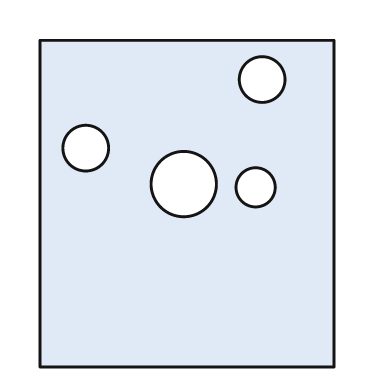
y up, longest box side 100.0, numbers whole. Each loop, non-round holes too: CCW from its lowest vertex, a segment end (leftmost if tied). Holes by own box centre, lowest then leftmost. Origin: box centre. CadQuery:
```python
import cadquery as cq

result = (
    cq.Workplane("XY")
    .moveTo(-45.0, -50.0)
    .lineTo(45.0, -50.0)
    .lineTo(45.0, 50.0)
    .lineTo(-45.0, 50.0)
    .close()
    .moveTo(21.0, 5.0)
    .circle(6.0)
    .moveTo(-1.0, 6.0)
    .circle(10.0)
    .moveTo(-31.0, 17.0)
    .circle(7.0)
    .moveTo(23.0, 38.0)
    .circle(7.0)
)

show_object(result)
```